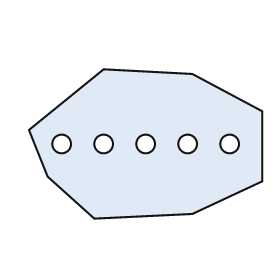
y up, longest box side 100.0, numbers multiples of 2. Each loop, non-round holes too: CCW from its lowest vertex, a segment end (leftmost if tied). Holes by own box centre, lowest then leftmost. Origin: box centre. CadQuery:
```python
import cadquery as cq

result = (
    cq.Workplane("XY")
    .moveTo(-22.0, -32.0)
    .lineTo(20.0, -30.0)
    .lineTo(50.0, -16.0)
    .lineTo(50.0, 14.0)
    .lineTo(20.0, 30.0)
    .lineTo(-18.0, 32.0)
    .lineTo(-50.0, 6.0)
    .lineTo(-42.0, -14.0)
    .close()
    .moveTo(-36.0, 0.0)
    .circle(4.0)
    .moveTo(-18.0, 0.0)
    .circle(4.0)
    .moveTo(0.0, 0.0)
    .circle(4.0)
    .moveTo(18.0, 0.0)
    .circle(4.0)
    .moveTo(36.0, 0.0)
    .circle(4.0)
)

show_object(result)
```